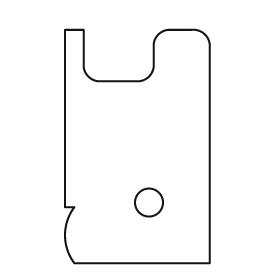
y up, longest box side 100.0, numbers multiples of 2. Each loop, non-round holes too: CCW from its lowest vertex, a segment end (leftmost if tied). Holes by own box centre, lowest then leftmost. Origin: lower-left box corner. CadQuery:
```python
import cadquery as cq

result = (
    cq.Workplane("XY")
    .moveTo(4.0, 0.0)
    .lineTo(62.0, 0.0)
    .lineTo(62.0, 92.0)
    .threePointArc((60.0, 98.0), (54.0, 100.0))
    .lineTo(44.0, 100.0)
    .threePointArc((40.0, 98.0), (38.0, 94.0))
    .lineTo(38.0, 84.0)
    .threePointArc((36.0, 80.0), (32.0, 78.0))
    .lineTo(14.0, 78.0)
    .threePointArc((10.0, 80.0), (8.0, 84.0))
    .lineTo(8.0, 100.0)
    .lineTo(0.0, 100.0)
    .lineTo(0.0, 24.0)
    .lineTo(4.0, 24.0)
    .threePointArc((0.0, 12.0), (4.0, 0.0))
    .close()
    .moveTo(36.0, 26.0)
    .circle(6.0)
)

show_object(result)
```